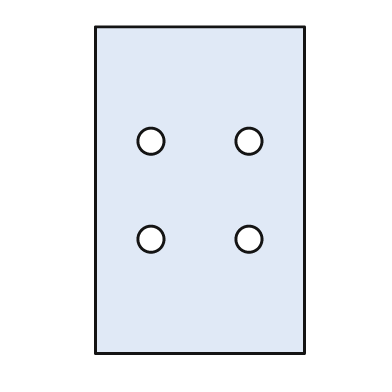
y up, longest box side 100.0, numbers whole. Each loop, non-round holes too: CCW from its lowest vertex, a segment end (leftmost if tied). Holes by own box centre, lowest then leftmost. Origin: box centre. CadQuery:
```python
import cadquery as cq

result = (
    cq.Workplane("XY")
    .moveTo(-32.0, -50.0)
    .lineTo(32.0, -50.0)
    .lineTo(32.0, 50.0)
    .lineTo(-32.0, 50.0)
    .close()
    .moveTo(-15.0, -15.0)
    .circle(4.0)
    .moveTo(15.0, -15.0)
    .circle(4.0)
    .moveTo(-15.0, 15.0)
    .circle(4.0)
    .moveTo(15.0, 15.0)
    .circle(4.0)
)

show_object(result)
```